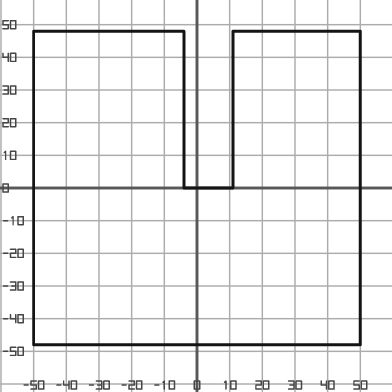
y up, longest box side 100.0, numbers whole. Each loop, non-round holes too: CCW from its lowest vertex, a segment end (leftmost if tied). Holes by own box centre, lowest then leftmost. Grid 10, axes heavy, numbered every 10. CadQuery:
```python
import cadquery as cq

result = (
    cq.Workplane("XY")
    .moveTo(-50.0, -48.0)
    .lineTo(50.0, -48.0)
    .lineTo(50.0, 48.0)
    .lineTo(11.0, 48.0)
    .lineTo(11.0, 0.0)
    .lineTo(-4.0, 0.0)
    .lineTo(-4.0, 48.0)
    .lineTo(-50.0, 48.0)
    .close()
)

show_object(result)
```